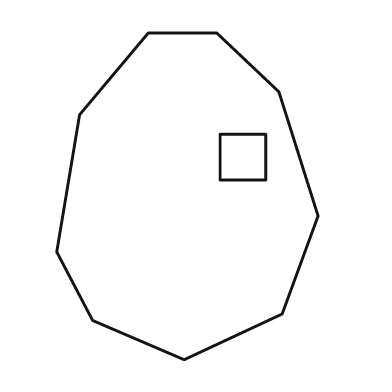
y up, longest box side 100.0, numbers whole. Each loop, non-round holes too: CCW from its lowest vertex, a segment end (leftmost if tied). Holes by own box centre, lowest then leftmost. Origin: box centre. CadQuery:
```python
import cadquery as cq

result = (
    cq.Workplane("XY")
    .moveTo(-1.0, -50.0)
    .lineTo(29.0, -36.0)
    .lineTo(40.0, -6.0)
    .lineTo(28.0, 32.0)
    .lineTo(9.0, 50.0)
    .lineTo(-12.0, 50.0)
    .lineTo(-33.0, 25.0)
    .lineTo(-40.0, -17.0)
    .lineTo(-29.0, -38.0)
    .close()
    .moveTo(10.0, 5.0)
    .lineTo(24.0, 5.0)
    .lineTo(24.0, 19.0)
    .lineTo(10.0, 19.0)
    .close()
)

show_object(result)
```